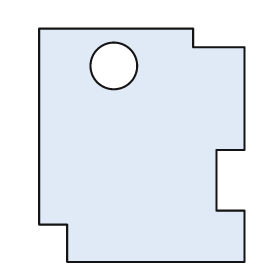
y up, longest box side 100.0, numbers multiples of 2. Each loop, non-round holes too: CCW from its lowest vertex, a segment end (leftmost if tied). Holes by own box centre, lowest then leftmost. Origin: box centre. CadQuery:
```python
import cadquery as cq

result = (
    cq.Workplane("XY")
    .moveTo(-32.0, -50.0)
    .lineTo(44.0, -50.0)
    .lineTo(44.0, -28.0)
    .lineTo(32.0, -28.0)
    .lineTo(32.0, -2.0)
    .lineTo(44.0, -2.0)
    .lineTo(44.0, 42.0)
    .lineTo(22.0, 42.0)
    .lineTo(22.0, 50.0)
    .lineTo(-44.0, 50.0)
    .lineTo(-44.0, -34.0)
    .lineTo(-32.0, -34.0)
    .close()
    .moveTo(-12.0, 34.0)
    .circle(10.0)
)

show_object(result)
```